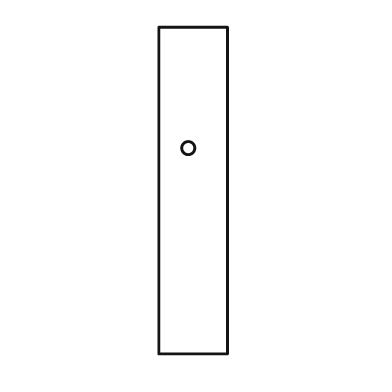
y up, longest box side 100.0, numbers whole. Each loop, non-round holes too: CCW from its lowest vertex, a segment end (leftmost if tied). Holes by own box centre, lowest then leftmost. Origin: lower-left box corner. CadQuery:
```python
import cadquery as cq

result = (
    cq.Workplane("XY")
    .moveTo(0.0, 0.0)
    .lineTo(21.0, 0.0)
    .lineTo(21.0, 100.0)
    .lineTo(0.0, 100.0)
    .close()
    .moveTo(9.0, 63.0)
    .circle(2.0)
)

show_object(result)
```